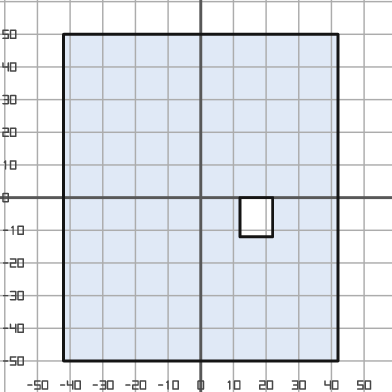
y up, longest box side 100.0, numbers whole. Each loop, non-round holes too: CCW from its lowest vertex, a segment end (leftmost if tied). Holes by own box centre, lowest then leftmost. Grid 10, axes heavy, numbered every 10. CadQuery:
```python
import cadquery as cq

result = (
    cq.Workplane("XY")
    .moveTo(-42.0, -50.0)
    .lineTo(42.0, -50.0)
    .lineTo(42.0, 50.0)
    .lineTo(-42.0, 50.0)
    .close()
    .moveTo(12.0, -12.0)
    .lineTo(22.0, -12.0)
    .lineTo(22.0, 0.0)
    .lineTo(12.0, 0.0)
    .close()
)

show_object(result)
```